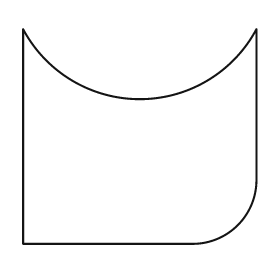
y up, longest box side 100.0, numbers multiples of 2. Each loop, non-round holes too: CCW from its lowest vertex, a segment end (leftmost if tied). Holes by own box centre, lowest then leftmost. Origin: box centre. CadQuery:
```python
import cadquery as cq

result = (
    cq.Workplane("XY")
    .moveTo(-50.0, -46.0)
    .lineTo(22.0, -46.0)
    .threePointArc((42.0, -38.0), (50.0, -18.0))
    .lineTo(50.0, 46.0)
    .threePointArc((0.0, 16.0), (-50.0, 46.0))
    .close()
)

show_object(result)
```